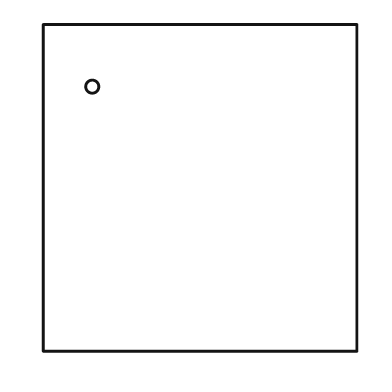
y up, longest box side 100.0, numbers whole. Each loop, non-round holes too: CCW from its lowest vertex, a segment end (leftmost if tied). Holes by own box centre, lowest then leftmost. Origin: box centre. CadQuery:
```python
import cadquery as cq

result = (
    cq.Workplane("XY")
    .moveTo(-48.0, -50.0)
    .lineTo(48.0, -50.0)
    .lineTo(48.0, 50.0)
    .lineTo(-48.0, 50.0)
    .close()
    .moveTo(-33.0, 31.0)
    .circle(2.0)
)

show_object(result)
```